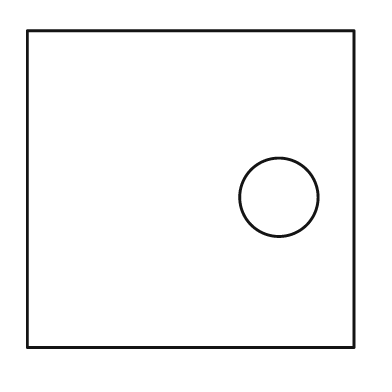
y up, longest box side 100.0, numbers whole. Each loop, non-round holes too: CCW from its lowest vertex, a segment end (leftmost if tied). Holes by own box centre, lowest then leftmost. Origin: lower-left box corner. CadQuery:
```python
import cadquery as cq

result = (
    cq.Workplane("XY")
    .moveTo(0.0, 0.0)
    .lineTo(100.0, 0.0)
    .lineTo(100.0, 97.0)
    .lineTo(0.0, 97.0)
    .close()
    .moveTo(77.0, 46.0)
    .circle(12.0)
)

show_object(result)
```